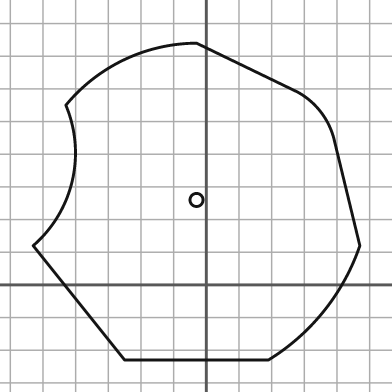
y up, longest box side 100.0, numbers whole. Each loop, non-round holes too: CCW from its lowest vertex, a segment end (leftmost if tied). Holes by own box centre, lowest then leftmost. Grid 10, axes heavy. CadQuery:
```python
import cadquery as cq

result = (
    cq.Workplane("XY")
    .moveTo(-25.0, -23.0)
    .lineTo(19.0, -23.0)
    .threePointArc((36.0, -8.0), (47.0, 12.0))
    .lineTo(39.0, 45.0)
    .threePointArc((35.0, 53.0), (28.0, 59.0))
    .lineTo(-3.0, 74.0)
    .threePointArc((-25.0, 69.0), (-43.0, 55.0))
    .threePointArc((-41.0, 32.0), (-53.0, 12.0))
    .close()
    .moveTo(-3.0, 26.0)
    .circle(2.0)
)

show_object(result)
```